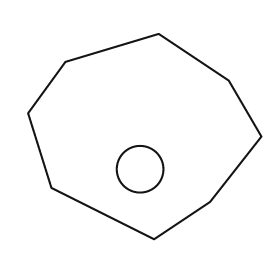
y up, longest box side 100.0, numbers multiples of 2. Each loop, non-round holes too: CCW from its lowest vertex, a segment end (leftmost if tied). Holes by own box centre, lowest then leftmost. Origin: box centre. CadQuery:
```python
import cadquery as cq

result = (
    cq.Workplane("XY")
    .moveTo(4.0, -44.0)
    .lineTo(28.0, -28.0)
    .lineTo(50.0, 0.0)
    .lineTo(36.0, 24.0)
    .lineTo(6.0, 44.0)
    .lineTo(-34.0, 32.0)
    .lineTo(-50.0, 10.0)
    .lineTo(-40.0, -22.0)
    .close()
    .moveTo(-2.0, -14.0)
    .circle(10.0)
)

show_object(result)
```